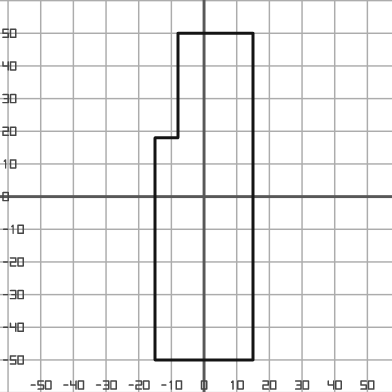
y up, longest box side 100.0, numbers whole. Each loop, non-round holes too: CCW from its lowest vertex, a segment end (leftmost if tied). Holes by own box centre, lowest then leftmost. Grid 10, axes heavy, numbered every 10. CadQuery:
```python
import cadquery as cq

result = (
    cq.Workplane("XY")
    .moveTo(-15.0, -50.0)
    .lineTo(15.0, -50.0)
    .lineTo(15.0, 50.0)
    .lineTo(-8.0, 50.0)
    .lineTo(-8.0, 18.0)
    .lineTo(-15.0, 18.0)
    .close()
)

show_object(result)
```